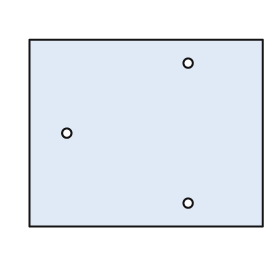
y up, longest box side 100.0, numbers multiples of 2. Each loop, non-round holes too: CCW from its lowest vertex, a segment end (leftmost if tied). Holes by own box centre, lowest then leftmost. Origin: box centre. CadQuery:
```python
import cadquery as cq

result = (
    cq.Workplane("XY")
    .moveTo(-50.0, -40.0)
    .lineTo(50.0, -40.0)
    .lineTo(50.0, 40.0)
    .lineTo(-50.0, 40.0)
    .close()
    .moveTo(18.0, -30.0)
    .circle(2.0)
    .moveTo(-34.0, 0.0)
    .circle(2.0)
    .moveTo(18.0, 30.0)
    .circle(2.0)
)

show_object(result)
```